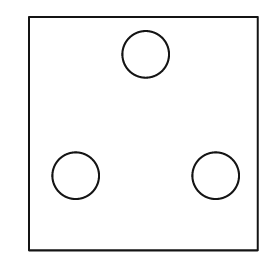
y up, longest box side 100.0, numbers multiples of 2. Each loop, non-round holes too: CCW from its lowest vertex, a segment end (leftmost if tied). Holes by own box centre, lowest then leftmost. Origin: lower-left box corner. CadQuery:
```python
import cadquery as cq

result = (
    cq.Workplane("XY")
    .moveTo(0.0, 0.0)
    .lineTo(98.0, 0.0)
    .lineTo(98.0, 100.0)
    .lineTo(0.0, 100.0)
    .close()
    .moveTo(20.0, 32.0)
    .circle(10.0)
    .moveTo(80.0, 32.0)
    .circle(10.0)
    .moveTo(50.0, 84.0)
    .circle(10.0)
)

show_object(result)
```